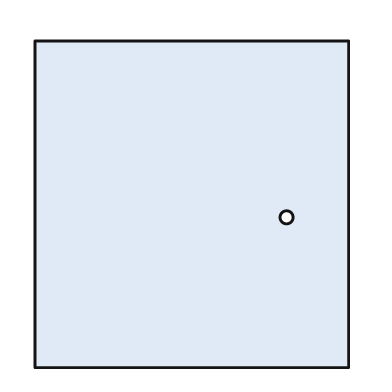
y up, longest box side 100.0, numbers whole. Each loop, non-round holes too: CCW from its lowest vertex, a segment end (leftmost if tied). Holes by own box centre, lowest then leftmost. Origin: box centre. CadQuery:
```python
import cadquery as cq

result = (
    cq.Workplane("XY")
    .moveTo(-48.0, -50.0)
    .lineTo(48.0, -50.0)
    .lineTo(48.0, 50.0)
    .lineTo(-48.0, 50.0)
    .close()
    .moveTo(29.0, -4.0)
    .circle(2.0)
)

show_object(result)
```